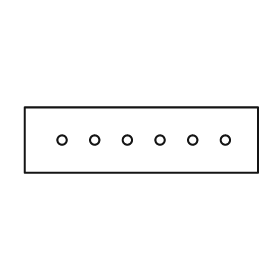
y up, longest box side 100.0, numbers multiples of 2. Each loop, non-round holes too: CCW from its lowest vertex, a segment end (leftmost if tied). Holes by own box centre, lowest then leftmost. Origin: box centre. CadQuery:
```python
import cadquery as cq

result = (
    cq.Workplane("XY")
    .moveTo(-50.0, -14.0)
    .lineTo(50.0, -14.0)
    .lineTo(50.0, 14.0)
    .lineTo(-50.0, 14.0)
    .close()
    .moveTo(-34.0, 0.0)
    .circle(2.0)
    .moveTo(-20.0, 0.0)
    .circle(2.0)
    .moveTo(-6.0, 0.0)
    .circle(2.0)
    .moveTo(8.0, 0.0)
    .circle(2.0)
    .moveTo(22.0, 0.0)
    .circle(2.0)
    .moveTo(36.0, 0.0)
    .circle(2.0)
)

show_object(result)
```